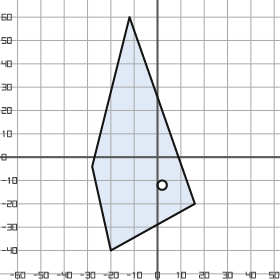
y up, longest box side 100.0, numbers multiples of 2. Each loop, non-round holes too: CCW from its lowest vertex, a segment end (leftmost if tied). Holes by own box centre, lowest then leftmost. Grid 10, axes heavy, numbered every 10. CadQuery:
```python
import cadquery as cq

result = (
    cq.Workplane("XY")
    .moveTo(-20.0, -40.0)
    .lineTo(16.0, -20.0)
    .lineTo(-12.0, 60.0)
    .lineTo(-28.0, -4.0)
    .close()
    .moveTo(2.0, -12.0)
    .circle(2.0)
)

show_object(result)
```